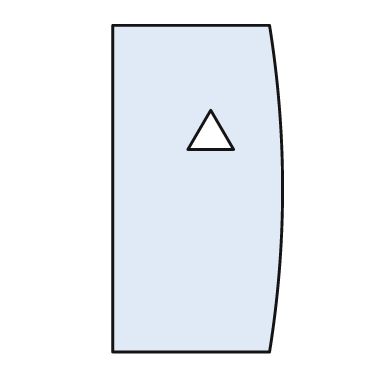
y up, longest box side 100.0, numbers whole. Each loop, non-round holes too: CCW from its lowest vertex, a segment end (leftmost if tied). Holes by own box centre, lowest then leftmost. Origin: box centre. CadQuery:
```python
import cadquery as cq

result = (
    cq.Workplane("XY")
    .moveTo(-26.0, -50.0)
    .lineTo(22.0, -50.0)
    .threePointArc((26.0, 0.0), (22.0, 50.0))
    .lineTo(-26.0, 50.0)
    .close()
    .moveTo(-3.0, 12.0)
    .lineTo(11.0, 12.0)
    .lineTo(4.0, 24.0)
    .close()
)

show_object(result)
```